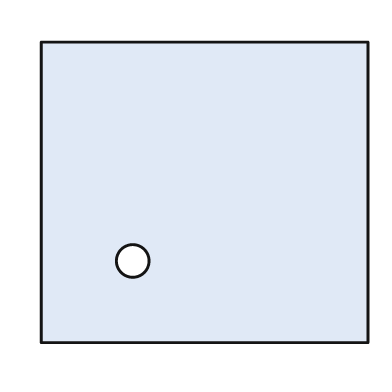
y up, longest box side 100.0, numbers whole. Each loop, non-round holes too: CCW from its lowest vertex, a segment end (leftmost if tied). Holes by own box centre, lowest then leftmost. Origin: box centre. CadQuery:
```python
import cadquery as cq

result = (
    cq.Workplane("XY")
    .moveTo(-50.0, -46.0)
    .lineTo(50.0, -46.0)
    .lineTo(50.0, 46.0)
    .lineTo(-50.0, 46.0)
    .close()
    .moveTo(-22.0, -21.0)
    .circle(5.0)
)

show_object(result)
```